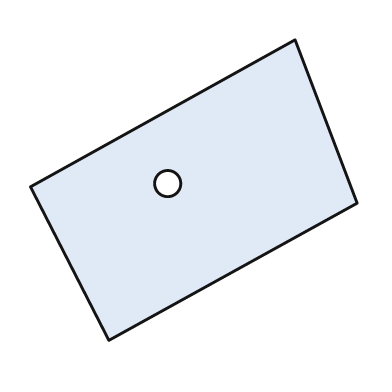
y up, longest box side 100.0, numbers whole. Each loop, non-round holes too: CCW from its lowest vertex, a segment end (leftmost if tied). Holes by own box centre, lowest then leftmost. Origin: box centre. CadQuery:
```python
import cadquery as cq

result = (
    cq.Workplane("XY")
    .moveTo(-26.0, -46.0)
    .lineTo(50.0, -4.0)
    .lineTo(31.0, 46.0)
    .lineTo(-50.0, 1.0)
    .close()
    .moveTo(-8.0, 2.0)
    .circle(4.0)
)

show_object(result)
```